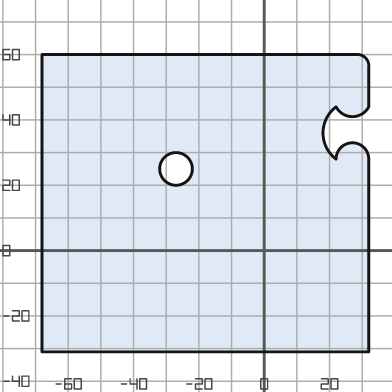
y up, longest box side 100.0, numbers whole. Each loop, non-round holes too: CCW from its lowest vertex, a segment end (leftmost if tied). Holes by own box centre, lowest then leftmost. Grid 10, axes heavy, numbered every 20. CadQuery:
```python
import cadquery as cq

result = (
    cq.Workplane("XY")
    .moveTo(-68.0, -31.0)
    .lineTo(32.0, -31.0)
    .lineTo(32.0, 28.0)
    .threePointArc((27.0, 33.0), (22.0, 28.0))
    .threePointArc((18.0, 36.0), (22.0, 44.0))
    .threePointArc((27.0, 41.0), (32.0, 44.0))
    .lineTo(32.0, 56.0)
    .threePointArc((31.0, 59.0), (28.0, 60.0))
    .lineTo(-68.0, 60.0)
    .close()
    .moveTo(-27.0, 25.0)
    .circle(5.0)
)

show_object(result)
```